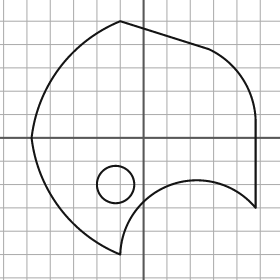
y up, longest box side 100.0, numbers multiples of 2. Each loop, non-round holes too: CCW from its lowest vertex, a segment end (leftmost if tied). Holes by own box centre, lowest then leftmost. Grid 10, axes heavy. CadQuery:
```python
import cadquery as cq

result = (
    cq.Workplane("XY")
    .moveTo(-10.0, -50.0)
    .threePointArc((12.0, -20.0), (48.0, -30.0))
    .lineTo(48.0, 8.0)
    .threePointArc((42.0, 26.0), (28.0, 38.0))
    .lineTo(-10.0, 50.0)
    .threePointArc((-36.0, 30.0), (-48.0, 0.0))
    .threePointArc((-36.0, -30.0), (-10.0, -50.0))
    .close()
    .moveTo(-12.0, -20.0)
    .circle(8.0)
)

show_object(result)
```